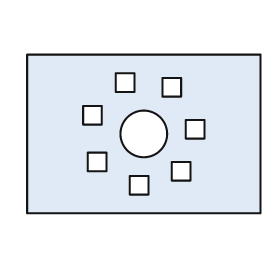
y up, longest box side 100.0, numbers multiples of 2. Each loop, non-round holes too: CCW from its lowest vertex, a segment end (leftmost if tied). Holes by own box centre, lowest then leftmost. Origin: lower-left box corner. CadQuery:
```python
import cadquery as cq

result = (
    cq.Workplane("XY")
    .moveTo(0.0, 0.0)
    .lineTo(100.0, 0.0)
    .lineTo(100.0, 68.0)
    .lineTo(0.0, 68.0)
    .close()
    .moveTo(44.0, 8.0)
    .lineTo(52.0, 8.0)
    .lineTo(52.0, 16.0)
    .lineTo(44.0, 16.0)
    .close()
    .moveTo(62.0, 14.0)
    .lineTo(70.0, 14.0)
    .lineTo(70.0, 22.0)
    .lineTo(62.0, 22.0)
    .close()
    .moveTo(26.0, 18.0)
    .lineTo(34.0, 18.0)
    .lineTo(34.0, 26.0)
    .lineTo(26.0, 26.0)
    .close()
    .moveTo(50.0, 34.0)
    .circle(10.0)
    .moveTo(68.0, 32.0)
    .lineTo(76.0, 32.0)
    .lineTo(76.0, 40.0)
    .lineTo(68.0, 40.0)
    .close()
    .moveTo(24.0, 38.0)
    .lineTo(32.0, 38.0)
    .lineTo(32.0, 46.0)
    .lineTo(24.0, 46.0)
    .close()
    .moveTo(58.0, 50.0)
    .lineTo(66.0, 50.0)
    .lineTo(66.0, 58.0)
    .lineTo(58.0, 58.0)
    .close()
    .moveTo(38.0, 52.0)
    .lineTo(46.0, 52.0)
    .lineTo(46.0, 60.0)
    .lineTo(38.0, 60.0)
    .close()
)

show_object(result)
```